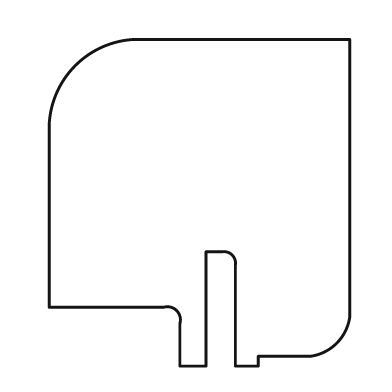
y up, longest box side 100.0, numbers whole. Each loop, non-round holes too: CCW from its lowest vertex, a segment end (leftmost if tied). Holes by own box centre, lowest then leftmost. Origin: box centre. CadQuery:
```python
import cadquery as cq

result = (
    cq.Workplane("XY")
    .moveTo(-6.0, -50.0)
    .lineTo(2.0, -50.0)
    .lineTo(2.0, -15.0)
    .lineTo(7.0, -15.0)
    .threePointArc((10.0, -16.0), (11.0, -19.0))
    .lineTo(11.0, -50.0)
    .lineTo(18.0, -50.0)
    .lineTo(18.0, -47.0)
    .lineTo(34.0, -47.0)
    .threePointArc((42.0, -43.0), (46.0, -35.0))
    .lineTo(46.0, 50.0)
    .lineTo(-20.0, 50.0)
    .threePointArc((-38.0, 42.0), (-46.0, 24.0))
    .lineTo(-46.0, -32.0)
    .lineTo(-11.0, -32.0)
    .threePointArc((-7.0, -33.0), (-6.0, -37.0))
    .close()
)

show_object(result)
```